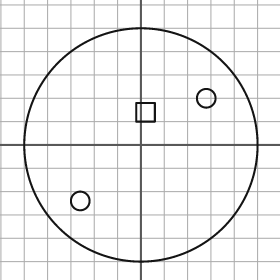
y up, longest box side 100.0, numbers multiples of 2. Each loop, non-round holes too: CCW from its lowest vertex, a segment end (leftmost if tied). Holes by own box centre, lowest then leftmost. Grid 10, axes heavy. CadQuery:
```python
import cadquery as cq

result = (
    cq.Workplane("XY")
    .moveTo(0.0, 0.0)
    .circle(50.0)
    .moveTo(-26.0, -24.0)
    .circle(4.0)
    .moveTo(-2.0, 10.0)
    .lineTo(6.0, 10.0)
    .lineTo(6.0, 18.0)
    .lineTo(-2.0, 18.0)
    .close()
    .moveTo(28.0, 20.0)
    .circle(4.0)
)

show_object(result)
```